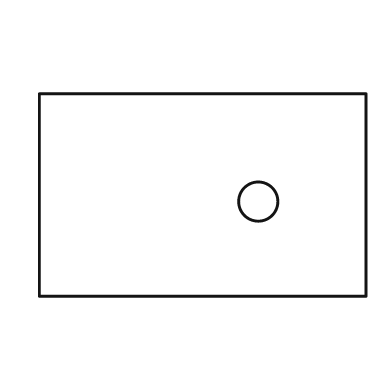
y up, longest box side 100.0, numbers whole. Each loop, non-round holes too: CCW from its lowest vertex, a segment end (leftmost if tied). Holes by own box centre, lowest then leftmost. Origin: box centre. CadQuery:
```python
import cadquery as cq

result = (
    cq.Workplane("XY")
    .moveTo(-50.0, -31.0)
    .lineTo(50.0, -31.0)
    .lineTo(50.0, 31.0)
    .lineTo(-50.0, 31.0)
    .close()
    .moveTo(17.0, -2.0)
    .circle(6.0)
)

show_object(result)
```